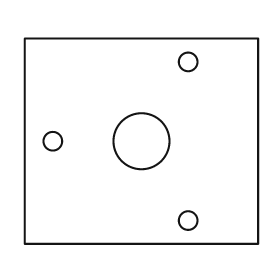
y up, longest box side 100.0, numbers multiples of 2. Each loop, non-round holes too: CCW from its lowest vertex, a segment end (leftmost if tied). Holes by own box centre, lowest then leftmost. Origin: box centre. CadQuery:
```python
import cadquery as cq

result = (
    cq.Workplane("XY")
    .moveTo(-50.0, -44.0)
    .lineTo(50.0, -44.0)
    .lineTo(50.0, 44.0)
    .lineTo(-50.0, 44.0)
    .close()
    .moveTo(20.0, -34.0)
    .circle(4.0)
    .moveTo(-38.0, 0.0)
    .circle(4.0)
    .moveTo(0.0, 0.0)
    .circle(12.0)
    .moveTo(20.0, 34.0)
    .circle(4.0)
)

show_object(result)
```